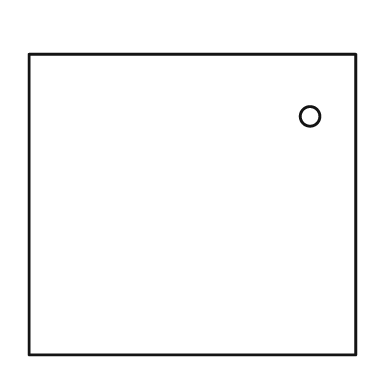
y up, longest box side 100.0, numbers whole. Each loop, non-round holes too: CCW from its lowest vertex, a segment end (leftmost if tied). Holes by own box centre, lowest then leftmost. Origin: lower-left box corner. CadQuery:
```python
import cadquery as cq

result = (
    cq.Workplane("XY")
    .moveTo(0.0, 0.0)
    .lineTo(100.0, 0.0)
    .lineTo(100.0, 92.0)
    .lineTo(0.0, 92.0)
    .close()
    .moveTo(86.0, 73.0)
    .circle(3.0)
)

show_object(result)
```